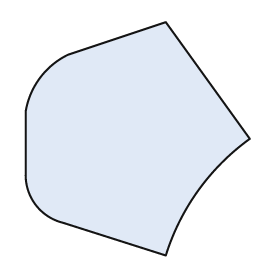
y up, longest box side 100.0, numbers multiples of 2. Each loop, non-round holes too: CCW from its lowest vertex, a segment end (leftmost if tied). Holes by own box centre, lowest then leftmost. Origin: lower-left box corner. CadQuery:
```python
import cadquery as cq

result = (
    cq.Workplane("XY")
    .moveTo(60.0, 0.0)
    .threePointArc((74.0, 28.0), (96.0, 50.0))
    .lineTo(60.0, 100.0)
    .lineTo(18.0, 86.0)
    .threePointArc((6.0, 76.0), (0.0, 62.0))
    .lineTo(0.0, 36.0)
    .threePointArc((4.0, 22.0), (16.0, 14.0))
    .close()
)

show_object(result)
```